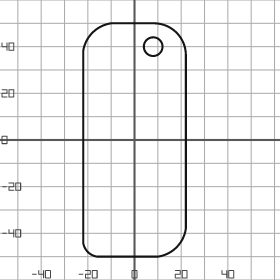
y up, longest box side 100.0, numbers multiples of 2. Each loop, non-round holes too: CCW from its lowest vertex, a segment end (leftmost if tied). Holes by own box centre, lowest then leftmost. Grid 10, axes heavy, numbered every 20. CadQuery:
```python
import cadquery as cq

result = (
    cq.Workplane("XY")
    .moveTo(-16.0, -50.0)
    .lineTo(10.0, -50.0)
    .threePointArc((18.0, -46.0), (22.0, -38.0))
    .lineTo(22.0, 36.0)
    .threePointArc((18.0, 46.0), (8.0, 50.0))
    .lineTo(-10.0, 50.0)
    .threePointArc((-18.0, 46.0), (-22.0, 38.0))
    .lineTo(-22.0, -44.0)
    .threePointArc((-20.0, -48.0), (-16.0, -50.0))
    .close()
    .moveTo(8.0, 40.0)
    .circle(4.0)
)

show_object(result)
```